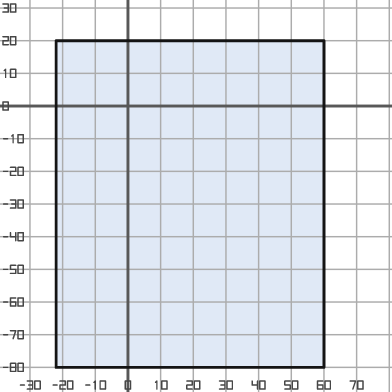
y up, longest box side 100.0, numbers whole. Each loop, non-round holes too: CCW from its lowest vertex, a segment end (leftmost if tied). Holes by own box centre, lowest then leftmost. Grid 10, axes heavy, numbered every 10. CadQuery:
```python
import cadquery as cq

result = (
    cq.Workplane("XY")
    .moveTo(-22.0, -80.0)
    .lineTo(60.0, -80.0)
    .lineTo(60.0, 20.0)
    .lineTo(-22.0, 20.0)
    .close()
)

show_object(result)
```